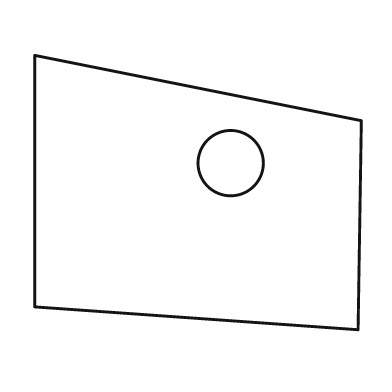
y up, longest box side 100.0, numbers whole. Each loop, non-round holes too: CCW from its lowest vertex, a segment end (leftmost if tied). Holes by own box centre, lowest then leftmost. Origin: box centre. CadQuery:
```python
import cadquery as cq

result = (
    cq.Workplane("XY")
    .moveTo(49.0, -42.0)
    .lineTo(50.0, 22.0)
    .lineTo(-50.0, 42.0)
    .lineTo(-50.0, -35.0)
    .close()
    .moveTo(10.0, 9.0)
    .circle(10.0)
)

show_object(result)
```